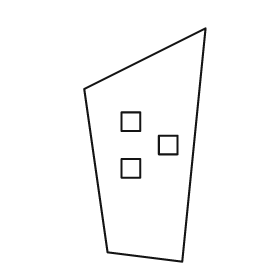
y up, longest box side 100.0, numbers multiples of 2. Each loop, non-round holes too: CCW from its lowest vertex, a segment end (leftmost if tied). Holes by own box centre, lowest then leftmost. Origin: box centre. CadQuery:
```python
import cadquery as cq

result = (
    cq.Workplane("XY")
    .moveTo(16.0, -50.0)
    .lineTo(26.0, 50.0)
    .lineTo(-26.0, 24.0)
    .lineTo(-16.0, -46.0)
    .close()
    .moveTo(-10.0, -14.0)
    .lineTo(-2.0, -14.0)
    .lineTo(-2.0, -6.0)
    .lineTo(-10.0, -6.0)
    .close()
    .moveTo(6.0, -4.0)
    .lineTo(14.0, -4.0)
    .lineTo(14.0, 4.0)
    .lineTo(6.0, 4.0)
    .close()
    .moveTo(-10.0, 6.0)
    .lineTo(-2.0, 6.0)
    .lineTo(-2.0, 14.0)
    .lineTo(-10.0, 14.0)
    .close()
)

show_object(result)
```